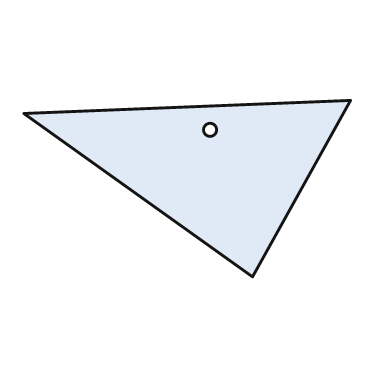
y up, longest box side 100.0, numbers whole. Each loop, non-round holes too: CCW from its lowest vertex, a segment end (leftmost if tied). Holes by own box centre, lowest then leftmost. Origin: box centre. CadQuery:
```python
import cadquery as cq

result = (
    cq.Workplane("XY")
    .moveTo(20.0, -27.0)
    .lineTo(50.0, 27.0)
    .lineTo(-50.0, 23.0)
    .close()
    .moveTo(7.0, 18.0)
    .circle(2.0)
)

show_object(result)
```